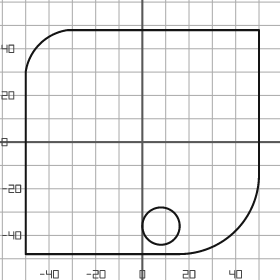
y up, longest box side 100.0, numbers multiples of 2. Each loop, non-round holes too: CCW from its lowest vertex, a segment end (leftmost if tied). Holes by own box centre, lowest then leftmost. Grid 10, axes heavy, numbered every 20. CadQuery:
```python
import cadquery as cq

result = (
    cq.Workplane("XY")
    .moveTo(-50.0, -48.0)
    .lineTo(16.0, -48.0)
    .threePointArc((40.0, -38.0), (50.0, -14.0))
    .lineTo(50.0, 48.0)
    .lineTo(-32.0, 48.0)
    .threePointArc((-44.0, 42.0), (-50.0, 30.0))
    .close()
    .moveTo(8.0, -36.0)
    .circle(8.0)
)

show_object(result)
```